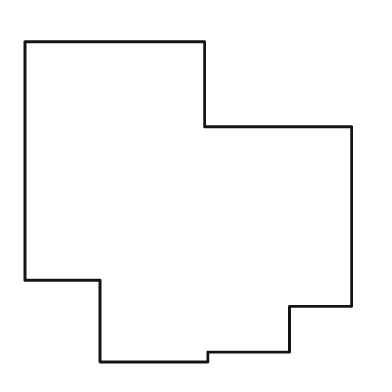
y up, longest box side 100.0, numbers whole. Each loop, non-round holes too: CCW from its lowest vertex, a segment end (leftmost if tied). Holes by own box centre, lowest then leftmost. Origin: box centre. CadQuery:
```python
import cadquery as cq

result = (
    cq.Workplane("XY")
    .moveTo(-27.0, -49.0)
    .lineTo(6.0, -49.0)
    .lineTo(6.0, -46.0)
    .lineTo(31.0, -46.0)
    .lineTo(31.0, -32.0)
    .lineTo(50.0, -32.0)
    .lineTo(50.0, 23.0)
    .lineTo(5.0, 23.0)
    .lineTo(5.0, 49.0)
    .lineTo(-50.0, 49.0)
    .lineTo(-50.0, -24.0)
    .lineTo(-27.0, -24.0)
    .close()
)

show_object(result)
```